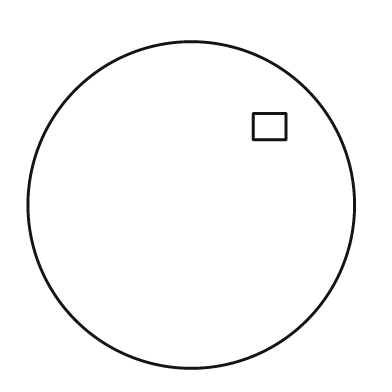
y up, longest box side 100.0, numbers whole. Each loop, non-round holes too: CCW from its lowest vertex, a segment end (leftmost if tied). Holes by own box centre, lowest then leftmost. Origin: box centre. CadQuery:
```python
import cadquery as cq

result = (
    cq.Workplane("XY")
    .moveTo(0.0, 0.0)
    .circle(50.0)
    .moveTo(19.0, 20.0)
    .lineTo(29.0, 20.0)
    .lineTo(29.0, 28.0)
    .lineTo(19.0, 28.0)
    .close()
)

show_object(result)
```